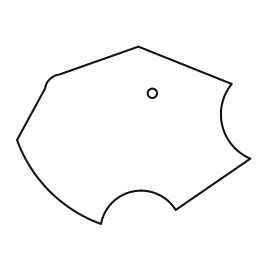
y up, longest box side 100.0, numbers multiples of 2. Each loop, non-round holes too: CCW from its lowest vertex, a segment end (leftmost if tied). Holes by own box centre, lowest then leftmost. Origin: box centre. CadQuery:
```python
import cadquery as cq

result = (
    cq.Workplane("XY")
    .moveTo(-14.0, -38.0)
    .threePointArc((0.0, -24.0), (18.0, -32.0))
    .lineTo(50.0, -10.0)
    .threePointArc((38.0, 4.0), (42.0, 22.0))
    .lineTo(2.0, 38.0)
    .lineTo(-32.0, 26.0)
    .threePointArc((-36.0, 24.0), (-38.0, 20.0))
    .lineTo(-50.0, -2.0)
    .threePointArc((-36.0, -24.0), (-14.0, -38.0))
    .close()
    .moveTo(8.0, 18.0)
    .circle(2.0)
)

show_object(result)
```